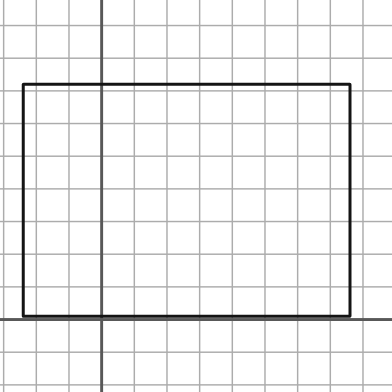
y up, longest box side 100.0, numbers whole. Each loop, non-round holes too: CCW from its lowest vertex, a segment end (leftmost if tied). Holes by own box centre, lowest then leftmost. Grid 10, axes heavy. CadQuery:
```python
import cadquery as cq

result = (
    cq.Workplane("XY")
    .moveTo(-24.0, 1.0)
    .lineTo(76.0, 1.0)
    .lineTo(76.0, 72.0)
    .lineTo(-24.0, 72.0)
    .close()
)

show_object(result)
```